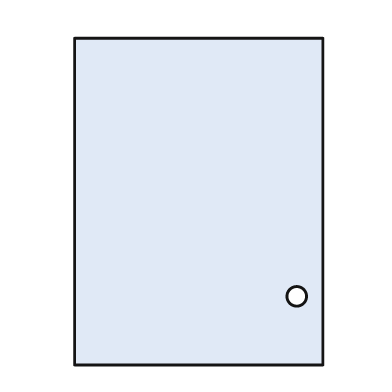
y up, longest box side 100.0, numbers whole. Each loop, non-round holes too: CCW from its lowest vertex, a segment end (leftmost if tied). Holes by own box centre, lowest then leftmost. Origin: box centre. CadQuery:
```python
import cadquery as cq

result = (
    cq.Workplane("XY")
    .moveTo(-38.0, -50.0)
    .lineTo(38.0, -50.0)
    .lineTo(38.0, 50.0)
    .lineTo(-38.0, 50.0)
    .close()
    .moveTo(30.0, -29.0)
    .circle(3.0)
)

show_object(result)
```